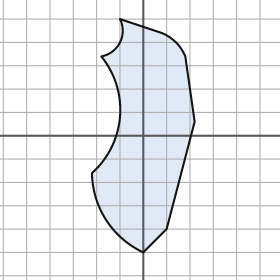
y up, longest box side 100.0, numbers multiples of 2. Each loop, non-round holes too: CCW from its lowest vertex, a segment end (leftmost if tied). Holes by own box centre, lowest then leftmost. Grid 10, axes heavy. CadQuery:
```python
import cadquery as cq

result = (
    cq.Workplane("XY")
    .moveTo(0.0, -50.0)
    .lineTo(10.0, -40.0)
    .lineTo(22.0, 6.0)
    .lineTo(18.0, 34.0)
    .threePointArc((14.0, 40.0), (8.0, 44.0))
    .lineTo(-10.0, 50.0)
    .threePointArc((-10.0, 40.0), (-18.0, 34.0))
    .threePointArc((-10.0, 8.0), (-22.0, -16.0))
    .threePointArc((-16.0, -36.0), (0.0, -50.0))
    .close()
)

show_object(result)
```